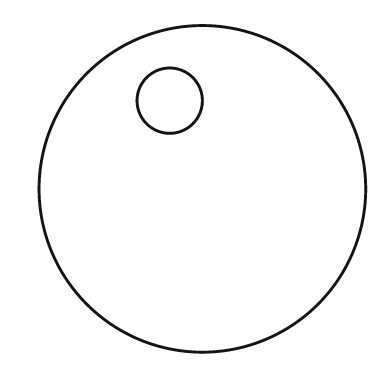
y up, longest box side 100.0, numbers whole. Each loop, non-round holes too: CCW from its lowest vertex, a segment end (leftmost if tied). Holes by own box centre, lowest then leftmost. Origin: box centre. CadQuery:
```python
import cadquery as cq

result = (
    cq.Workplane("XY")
    .moveTo(0.0, 0.0)
    .circle(50.0)
    .moveTo(-10.0, 27.0)
    .circle(10.0)
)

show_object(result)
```